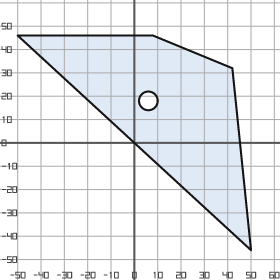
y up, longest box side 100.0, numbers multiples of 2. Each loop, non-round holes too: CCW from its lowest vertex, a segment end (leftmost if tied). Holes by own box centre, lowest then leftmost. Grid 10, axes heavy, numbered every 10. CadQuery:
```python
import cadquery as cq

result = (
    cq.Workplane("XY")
    .moveTo(50.0, -46.0)
    .lineTo(42.0, 32.0)
    .lineTo(8.0, 46.0)
    .lineTo(-50.0, 46.0)
    .close()
    .moveTo(6.0, 18.0)
    .circle(4.0)
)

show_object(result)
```